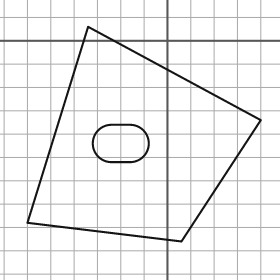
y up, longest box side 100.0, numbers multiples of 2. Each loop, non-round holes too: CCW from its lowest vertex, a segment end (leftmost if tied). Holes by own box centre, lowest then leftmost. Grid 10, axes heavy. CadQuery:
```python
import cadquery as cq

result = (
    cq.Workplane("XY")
    .moveTo(6.0, -86.0)
    .lineTo(40.0, -34.0)
    .lineTo(-34.0, 6.0)
    .lineTo(-60.0, -78.0)
    .close()
    .moveTo(-24.0, -52.0)
    .lineTo(-16.0, -52.0)
    .threePointArc((-8.0, -44.0), (-16.0, -36.0))
    .lineTo(-24.0, -36.0)
    .threePointArc((-32.0, -44.0), (-24.0, -52.0))
    .close()
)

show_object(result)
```